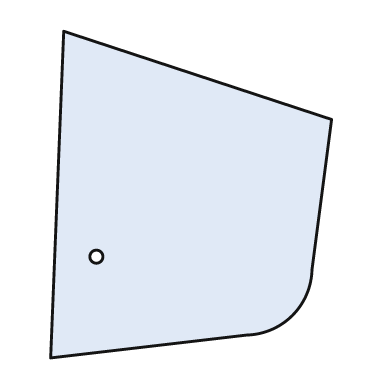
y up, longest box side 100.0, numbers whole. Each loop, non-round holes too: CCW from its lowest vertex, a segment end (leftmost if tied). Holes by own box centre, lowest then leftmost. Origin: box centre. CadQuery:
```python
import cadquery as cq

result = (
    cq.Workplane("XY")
    .moveTo(-43.0, -50.0)
    .lineTo(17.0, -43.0)
    .threePointArc((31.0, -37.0), (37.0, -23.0))
    .lineTo(43.0, 23.0)
    .lineTo(-39.0, 50.0)
    .close()
    .moveTo(-29.0, -19.0)
    .circle(2.0)
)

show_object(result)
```